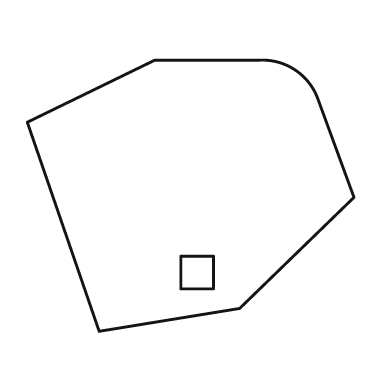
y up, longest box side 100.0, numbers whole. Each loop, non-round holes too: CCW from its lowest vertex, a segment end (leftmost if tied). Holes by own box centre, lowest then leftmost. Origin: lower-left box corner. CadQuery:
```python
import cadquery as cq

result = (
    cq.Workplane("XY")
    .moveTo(22.0, 0.0)
    .lineTo(65.0, 7.0)
    .lineTo(100.0, 41.0)
    .lineTo(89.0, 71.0)
    .threePointArc((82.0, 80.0), (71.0, 83.0))
    .lineTo(39.0, 83.0)
    .lineTo(0.0, 64.0)
    .close()
    .moveTo(47.0, 13.0)
    .lineTo(57.0, 13.0)
    .lineTo(57.0, 23.0)
    .lineTo(47.0, 23.0)
    .close()
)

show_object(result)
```